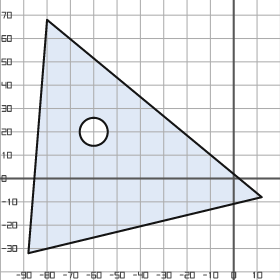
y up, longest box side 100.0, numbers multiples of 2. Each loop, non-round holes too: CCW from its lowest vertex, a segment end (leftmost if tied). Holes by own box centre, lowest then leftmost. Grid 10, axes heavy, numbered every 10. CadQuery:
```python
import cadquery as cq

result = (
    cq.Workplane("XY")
    .moveTo(-88.0, -32.0)
    .lineTo(12.0, -8.0)
    .lineTo(-80.0, 68.0)
    .close()
    .moveTo(-60.0, 20.0)
    .circle(6.0)
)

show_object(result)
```